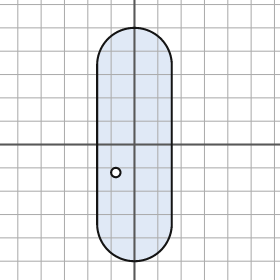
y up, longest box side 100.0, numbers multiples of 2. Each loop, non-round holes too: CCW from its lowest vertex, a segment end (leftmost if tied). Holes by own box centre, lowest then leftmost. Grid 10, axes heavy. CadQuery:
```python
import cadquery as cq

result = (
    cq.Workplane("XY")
    .moveTo(-16.0, -34.0)
    .threePointArc((0.0, -50.0), (16.0, -34.0))
    .lineTo(16.0, 34.0)
    .threePointArc((0.0, 50.0), (-16.0, 34.0))
    .close()
    .moveTo(-8.0, -12.0)
    .circle(2.0)
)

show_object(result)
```